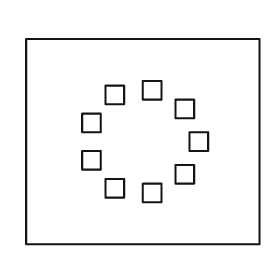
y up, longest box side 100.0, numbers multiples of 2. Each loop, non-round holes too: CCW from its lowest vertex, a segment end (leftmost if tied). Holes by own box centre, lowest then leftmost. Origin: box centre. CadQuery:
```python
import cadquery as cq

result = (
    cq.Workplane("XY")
    .moveTo(-50.0, -44.0)
    .lineTo(50.0, -44.0)
    .lineTo(50.0, 44.0)
    .lineTo(-50.0, 44.0)
    .close()
    .moveTo(0.0, -26.0)
    .lineTo(8.0, -26.0)
    .lineTo(8.0, -18.0)
    .lineTo(0.0, -18.0)
    .close()
    .moveTo(-16.0, -24.0)
    .lineTo(-8.0, -24.0)
    .lineTo(-8.0, -16.0)
    .lineTo(-16.0, -16.0)
    .close()
    .moveTo(14.0, -18.0)
    .lineTo(22.0, -18.0)
    .lineTo(22.0, -10.0)
    .lineTo(14.0, -10.0)
    .close()
    .moveTo(-26.0, -12.0)
    .lineTo(-18.0, -12.0)
    .lineTo(-18.0, -4.0)
    .lineTo(-26.0, -4.0)
    .close()
    .moveTo(20.0, -4.0)
    .lineTo(28.0, -4.0)
    .lineTo(28.0, 4.0)
    .lineTo(20.0, 4.0)
    .close()
    .moveTo(-26.0, 4.0)
    .lineTo(-18.0, 4.0)
    .lineTo(-18.0, 12.0)
    .lineTo(-26.0, 12.0)
    .close()
    .moveTo(14.0, 10.0)
    .lineTo(22.0, 10.0)
    .lineTo(22.0, 18.0)
    .lineTo(14.0, 18.0)
    .close()
    .moveTo(-16.0, 16.0)
    .lineTo(-8.0, 16.0)
    .lineTo(-8.0, 24.0)
    .lineTo(-16.0, 24.0)
    .close()
    .moveTo(0.0, 18.0)
    .lineTo(8.0, 18.0)
    .lineTo(8.0, 26.0)
    .lineTo(0.0, 26.0)
    .close()
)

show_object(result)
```